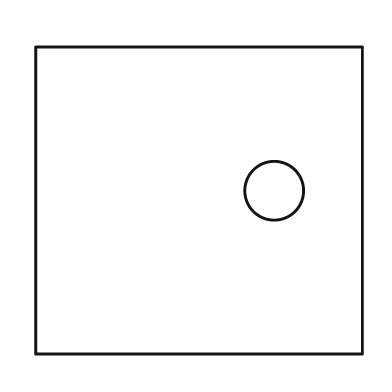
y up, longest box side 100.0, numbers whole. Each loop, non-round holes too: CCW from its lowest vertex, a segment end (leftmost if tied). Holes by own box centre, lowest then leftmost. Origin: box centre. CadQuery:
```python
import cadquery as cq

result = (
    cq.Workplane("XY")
    .moveTo(-50.0, -47.0)
    .lineTo(50.0, -47.0)
    .lineTo(50.0, 47.0)
    .lineTo(-50.0, 47.0)
    .close()
    .moveTo(23.0, 3.0)
    .circle(9.0)
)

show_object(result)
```